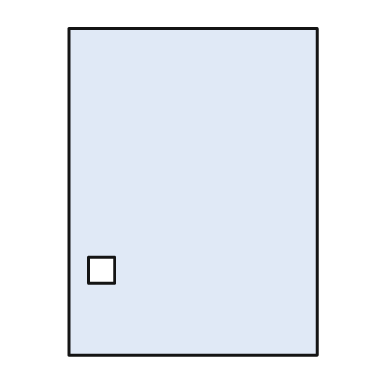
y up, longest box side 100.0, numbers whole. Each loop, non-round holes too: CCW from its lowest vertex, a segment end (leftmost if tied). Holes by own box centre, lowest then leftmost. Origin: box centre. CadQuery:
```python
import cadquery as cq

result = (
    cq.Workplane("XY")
    .moveTo(-38.0, -50.0)
    .lineTo(38.0, -50.0)
    .lineTo(38.0, 50.0)
    .lineTo(-38.0, 50.0)
    .close()
    .moveTo(-32.0, -28.0)
    .lineTo(-24.0, -28.0)
    .lineTo(-24.0, -20.0)
    .lineTo(-32.0, -20.0)
    .close()
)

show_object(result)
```